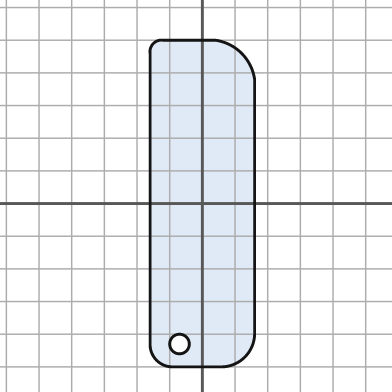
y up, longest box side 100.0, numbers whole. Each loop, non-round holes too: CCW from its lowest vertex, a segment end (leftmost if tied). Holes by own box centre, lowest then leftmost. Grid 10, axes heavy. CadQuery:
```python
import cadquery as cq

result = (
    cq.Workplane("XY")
    .moveTo(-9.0, -50.0)
    .lineTo(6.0, -50.0)
    .threePointArc((13.0, -47.0), (16.0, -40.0))
    .lineTo(16.0, 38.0)
    .threePointArc((12.0, 46.0), (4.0, 50.0))
    .lineTo(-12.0, 50.0)
    .threePointArc((-15.0, 49.0), (-16.0, 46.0))
    .lineTo(-16.0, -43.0)
    .threePointArc((-14.0, -48.0), (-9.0, -50.0))
    .close()
    .moveTo(-7.0, -43.0)
    .circle(3.0)
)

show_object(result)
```